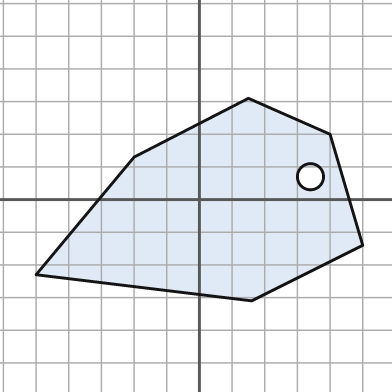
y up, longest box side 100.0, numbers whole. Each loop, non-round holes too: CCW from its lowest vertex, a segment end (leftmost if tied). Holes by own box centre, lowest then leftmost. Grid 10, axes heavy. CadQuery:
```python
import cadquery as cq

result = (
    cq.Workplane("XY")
    .moveTo(16.0, -31.0)
    .lineTo(50.0, -14.0)
    .lineTo(40.0, 20.0)
    .lineTo(15.0, 31.0)
    .lineTo(-20.0, 13.0)
    .lineTo(-50.0, -23.0)
    .close()
    .moveTo(34.0, 7.0)
    .circle(4.0)
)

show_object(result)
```